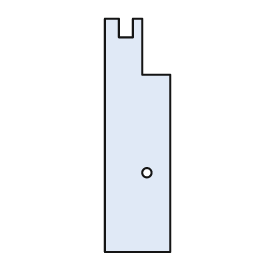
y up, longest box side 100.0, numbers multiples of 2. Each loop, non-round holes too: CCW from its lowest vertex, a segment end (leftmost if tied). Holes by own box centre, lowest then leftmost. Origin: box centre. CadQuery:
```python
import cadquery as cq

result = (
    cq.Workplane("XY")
    .moveTo(-14.0, -50.0)
    .lineTo(14.0, -50.0)
    .lineTo(14.0, 26.0)
    .lineTo(2.0, 26.0)
    .lineTo(2.0, 50.0)
    .lineTo(-2.0, 50.0)
    .lineTo(-2.0, 42.0)
    .lineTo(-8.0, 42.0)
    .lineTo(-8.0, 50.0)
    .lineTo(-14.0, 50.0)
    .close()
    .moveTo(4.0, -16.0)
    .circle(2.0)
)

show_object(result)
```